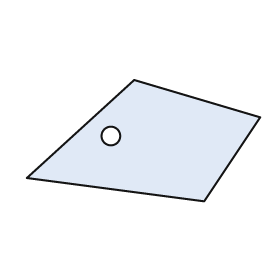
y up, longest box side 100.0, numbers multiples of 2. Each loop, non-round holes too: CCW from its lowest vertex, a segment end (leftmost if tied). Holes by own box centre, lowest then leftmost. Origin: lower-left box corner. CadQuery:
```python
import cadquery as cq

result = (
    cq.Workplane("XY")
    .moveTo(76.0, 0.0)
    .lineTo(100.0, 36.0)
    .lineTo(46.0, 52.0)
    .lineTo(0.0, 10.0)
    .close()
    .moveTo(36.0, 28.0)
    .circle(4.0)
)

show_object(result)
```